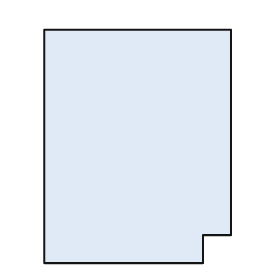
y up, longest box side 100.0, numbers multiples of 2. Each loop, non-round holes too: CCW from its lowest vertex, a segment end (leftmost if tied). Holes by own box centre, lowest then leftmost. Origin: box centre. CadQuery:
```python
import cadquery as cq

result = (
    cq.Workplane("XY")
    .moveTo(-40.0, -50.0)
    .lineTo(28.0, -50.0)
    .lineTo(28.0, -38.0)
    .lineTo(40.0, -38.0)
    .lineTo(40.0, 50.0)
    .lineTo(-40.0, 50.0)
    .close()
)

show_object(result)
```